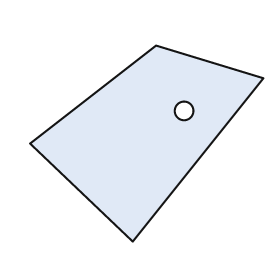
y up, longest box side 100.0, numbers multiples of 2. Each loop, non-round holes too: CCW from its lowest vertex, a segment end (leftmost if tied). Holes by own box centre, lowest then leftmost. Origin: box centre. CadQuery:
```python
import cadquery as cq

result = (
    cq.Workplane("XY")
    .moveTo(-6.0, -42.0)
    .lineTo(50.0, 28.0)
    .lineTo(4.0, 42.0)
    .lineTo(-50.0, 0.0)
    .close()
    .moveTo(16.0, 14.0)
    .circle(4.0)
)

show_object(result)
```